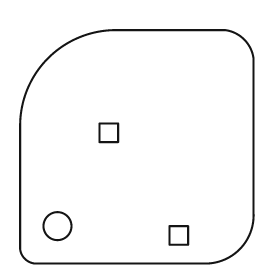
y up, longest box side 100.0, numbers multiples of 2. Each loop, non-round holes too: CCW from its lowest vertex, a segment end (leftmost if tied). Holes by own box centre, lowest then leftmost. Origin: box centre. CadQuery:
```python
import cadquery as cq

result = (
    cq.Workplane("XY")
    .moveTo(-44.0, -50.0)
    .lineTo(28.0, -50.0)
    .threePointArc((44.0, -44.0), (50.0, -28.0))
    .lineTo(50.0, 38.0)
    .threePointArc((46.0, 46.0), (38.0, 50.0))
    .lineTo(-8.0, 50.0)
    .threePointArc((-38.0, 38.0), (-50.0, 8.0))
    .lineTo(-50.0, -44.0)
    .threePointArc((-48.0, -48.0), (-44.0, -50.0))
    .close()
    .moveTo(14.0, -42.0)
    .lineTo(22.0, -42.0)
    .lineTo(22.0, -34.0)
    .lineTo(14.0, -34.0)
    .close()
    .moveTo(-34.0, -34.0)
    .circle(6.0)
    .moveTo(-16.0, 2.0)
    .lineTo(-8.0, 2.0)
    .lineTo(-8.0, 10.0)
    .lineTo(-16.0, 10.0)
    .close()
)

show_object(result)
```